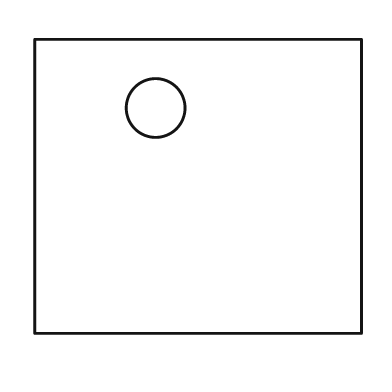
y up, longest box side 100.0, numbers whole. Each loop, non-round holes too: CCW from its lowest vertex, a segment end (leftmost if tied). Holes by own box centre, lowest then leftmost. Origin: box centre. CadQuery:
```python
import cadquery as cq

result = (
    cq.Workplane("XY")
    .moveTo(-50.0, -45.0)
    .lineTo(50.0, -45.0)
    .lineTo(50.0, 45.0)
    .lineTo(-50.0, 45.0)
    .close()
    .moveTo(-13.0, 24.0)
    .circle(9.0)
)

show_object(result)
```